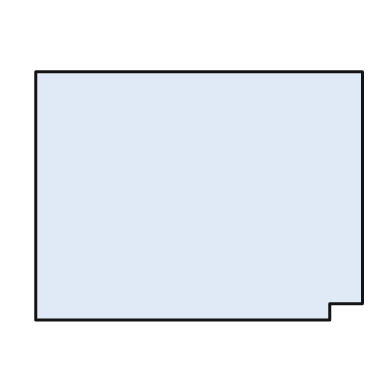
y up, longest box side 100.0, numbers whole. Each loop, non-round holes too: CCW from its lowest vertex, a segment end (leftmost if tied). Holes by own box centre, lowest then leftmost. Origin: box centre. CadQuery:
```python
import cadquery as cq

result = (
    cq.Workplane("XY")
    .moveTo(-50.0, -38.0)
    .lineTo(40.0, -38.0)
    .lineTo(40.0, -33.0)
    .lineTo(50.0, -33.0)
    .lineTo(50.0, 38.0)
    .lineTo(-50.0, 38.0)
    .close()
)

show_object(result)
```